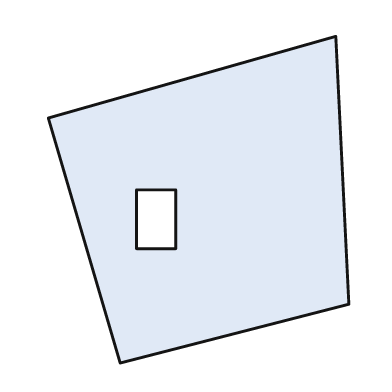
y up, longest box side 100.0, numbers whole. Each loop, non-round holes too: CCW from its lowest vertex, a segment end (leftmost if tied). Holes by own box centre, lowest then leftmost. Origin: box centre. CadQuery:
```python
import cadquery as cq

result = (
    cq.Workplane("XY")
    .moveTo(-24.0, -50.0)
    .lineTo(46.0, -32.0)
    .lineTo(42.0, 50.0)
    .lineTo(-46.0, 25.0)
    .close()
    .moveTo(-19.0, -15.0)
    .lineTo(-7.0, -15.0)
    .lineTo(-7.0, 3.0)
    .lineTo(-19.0, 3.0)
    .close()
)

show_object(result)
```